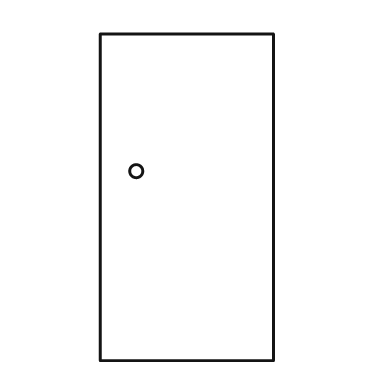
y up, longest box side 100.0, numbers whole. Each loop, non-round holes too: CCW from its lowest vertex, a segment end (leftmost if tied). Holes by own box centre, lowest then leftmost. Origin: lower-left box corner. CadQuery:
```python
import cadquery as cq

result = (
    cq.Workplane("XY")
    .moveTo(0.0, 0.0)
    .lineTo(53.0, 0.0)
    .lineTo(53.0, 100.0)
    .lineTo(0.0, 100.0)
    .close()
    .moveTo(11.0, 58.0)
    .circle(2.0)
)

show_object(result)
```